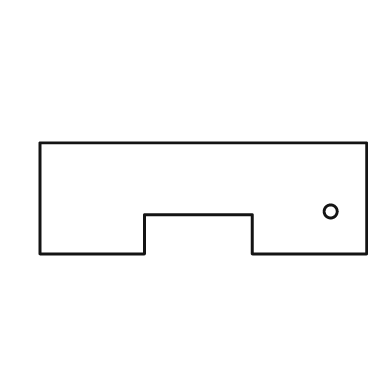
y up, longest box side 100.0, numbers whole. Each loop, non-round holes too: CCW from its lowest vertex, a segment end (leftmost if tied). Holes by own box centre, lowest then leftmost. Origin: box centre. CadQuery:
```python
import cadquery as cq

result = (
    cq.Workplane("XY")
    .moveTo(-50.0, -17.0)
    .lineTo(-18.0, -17.0)
    .lineTo(-18.0, -5.0)
    .lineTo(15.0, -5.0)
    .lineTo(15.0, -17.0)
    .lineTo(50.0, -17.0)
    .lineTo(50.0, 17.0)
    .lineTo(-50.0, 17.0)
    .close()
    .moveTo(39.0, -4.0)
    .circle(2.0)
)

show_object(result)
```